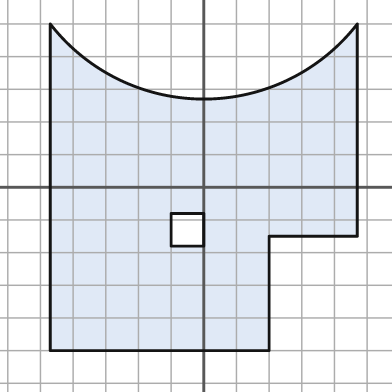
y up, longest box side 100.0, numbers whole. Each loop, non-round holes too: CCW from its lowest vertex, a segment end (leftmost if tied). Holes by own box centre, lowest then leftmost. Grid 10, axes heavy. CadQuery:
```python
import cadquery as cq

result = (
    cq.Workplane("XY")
    .moveTo(-47.0, -50.0)
    .lineTo(20.0, -50.0)
    .lineTo(20.0, -15.0)
    .lineTo(47.0, -15.0)
    .lineTo(47.0, 50.0)
    .threePointArc((0.0, 27.0), (-47.0, 50.0))
    .close()
    .moveTo(-10.0, -18.0)
    .lineTo(0.0, -18.0)
    .lineTo(0.0, -8.0)
    .lineTo(-10.0, -8.0)
    .close()
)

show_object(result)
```